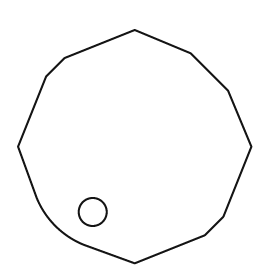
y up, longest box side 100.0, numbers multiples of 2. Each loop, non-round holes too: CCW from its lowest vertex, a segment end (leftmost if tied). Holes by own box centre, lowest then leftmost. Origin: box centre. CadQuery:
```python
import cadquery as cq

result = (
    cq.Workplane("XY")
    .moveTo(0.0, -50.0)
    .lineTo(30.0, -38.0)
    .lineTo(38.0, -30.0)
    .lineTo(50.0, 0.0)
    .lineTo(40.0, 24.0)
    .lineTo(24.0, 40.0)
    .lineTo(0.0, 50.0)
    .lineTo(-30.0, 38.0)
    .lineTo(-38.0, 30.0)
    .lineTo(-50.0, 0.0)
    .lineTo(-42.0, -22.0)
    .threePointArc((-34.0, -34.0), (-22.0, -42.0))
    .close()
    .moveTo(-18.0, -28.0)
    .circle(6.0)
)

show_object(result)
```